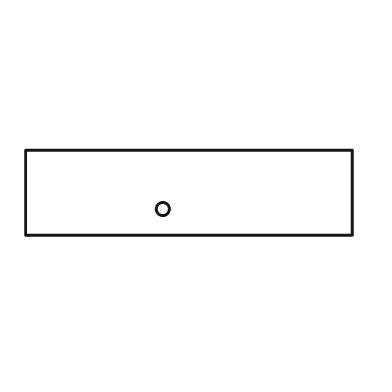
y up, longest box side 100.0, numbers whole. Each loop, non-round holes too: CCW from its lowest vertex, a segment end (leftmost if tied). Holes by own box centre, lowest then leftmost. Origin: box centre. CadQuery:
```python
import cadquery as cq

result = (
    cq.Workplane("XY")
    .moveTo(-50.0, -13.0)
    .lineTo(50.0, -13.0)
    .lineTo(50.0, 13.0)
    .lineTo(-50.0, 13.0)
    .close()
    .moveTo(-8.0, -5.0)
    .circle(2.0)
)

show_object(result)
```